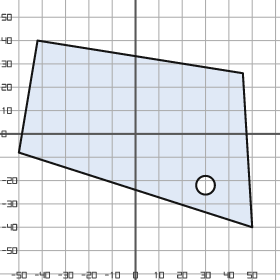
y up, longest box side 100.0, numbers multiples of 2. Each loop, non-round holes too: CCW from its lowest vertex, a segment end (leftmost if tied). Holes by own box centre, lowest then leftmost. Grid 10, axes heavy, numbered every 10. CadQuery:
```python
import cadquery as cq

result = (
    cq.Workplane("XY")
    .moveTo(50.0, -40.0)
    .lineTo(46.0, 26.0)
    .lineTo(-42.0, 40.0)
    .lineTo(-50.0, -8.0)
    .close()
    .moveTo(30.0, -22.0)
    .circle(4.0)
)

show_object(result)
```